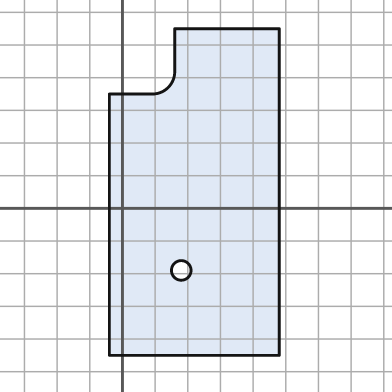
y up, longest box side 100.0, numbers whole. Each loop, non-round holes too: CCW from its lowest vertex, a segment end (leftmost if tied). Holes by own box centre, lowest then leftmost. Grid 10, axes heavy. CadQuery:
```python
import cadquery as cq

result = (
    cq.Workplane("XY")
    .moveTo(-4.0, -45.0)
    .lineTo(48.0, -45.0)
    .lineTo(48.0, 55.0)
    .lineTo(16.0, 55.0)
    .lineTo(16.0, 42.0)
    .threePointArc((14.0, 37.0), (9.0, 35.0))
    .lineTo(-4.0, 35.0)
    .close()
    .moveTo(18.0, -19.0)
    .circle(3.0)
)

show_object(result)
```